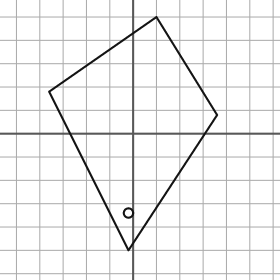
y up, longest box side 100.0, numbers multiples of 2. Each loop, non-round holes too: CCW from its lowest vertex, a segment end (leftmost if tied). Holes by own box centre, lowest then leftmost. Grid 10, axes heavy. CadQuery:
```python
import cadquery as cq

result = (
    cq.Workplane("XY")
    .moveTo(-2.0, -50.0)
    .lineTo(36.0, 8.0)
    .lineTo(10.0, 50.0)
    .lineTo(-36.0, 18.0)
    .close()
    .moveTo(-2.0, -34.0)
    .circle(2.0)
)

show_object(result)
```